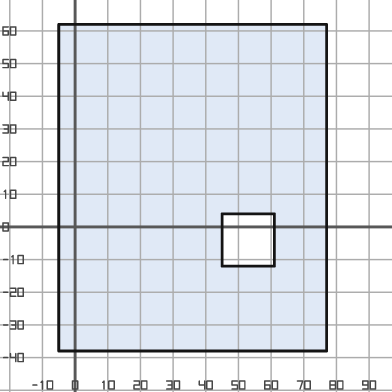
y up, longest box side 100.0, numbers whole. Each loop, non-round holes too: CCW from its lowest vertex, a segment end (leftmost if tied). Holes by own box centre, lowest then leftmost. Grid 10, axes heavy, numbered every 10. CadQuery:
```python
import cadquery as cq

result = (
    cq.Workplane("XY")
    .moveTo(-5.0, -38.0)
    .lineTo(77.0, -38.0)
    .lineTo(77.0, 62.0)
    .lineTo(-5.0, 62.0)
    .close()
    .moveTo(45.0, -12.0)
    .lineTo(61.0, -12.0)
    .lineTo(61.0, 4.0)
    .lineTo(45.0, 4.0)
    .close()
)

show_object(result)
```